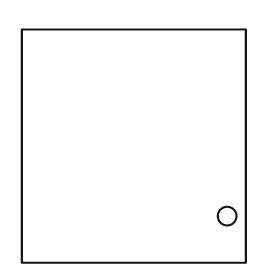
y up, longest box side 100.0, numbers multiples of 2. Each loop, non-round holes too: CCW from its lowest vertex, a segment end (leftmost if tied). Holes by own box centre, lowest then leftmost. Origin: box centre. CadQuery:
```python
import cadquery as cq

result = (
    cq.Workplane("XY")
    .moveTo(-48.0, -50.0)
    .lineTo(48.0, -50.0)
    .lineTo(48.0, 50.0)
    .lineTo(-48.0, 50.0)
    .close()
    .moveTo(40.0, -30.0)
    .circle(4.0)
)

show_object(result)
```